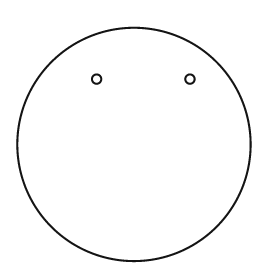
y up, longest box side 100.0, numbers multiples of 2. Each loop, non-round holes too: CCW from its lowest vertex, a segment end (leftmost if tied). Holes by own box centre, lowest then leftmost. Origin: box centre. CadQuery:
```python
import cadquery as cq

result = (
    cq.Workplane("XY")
    .moveTo(0.0, 0.0)
    .circle(50.0)
    .moveTo(-16.0, 28.0)
    .circle(2.0)
    .moveTo(24.0, 28.0)
    .circle(2.0)
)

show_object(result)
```